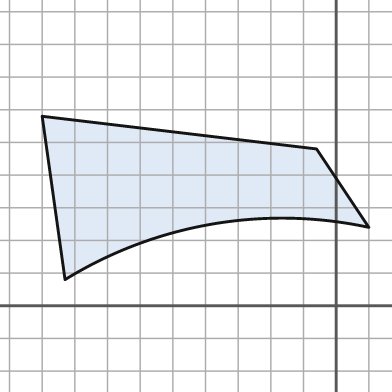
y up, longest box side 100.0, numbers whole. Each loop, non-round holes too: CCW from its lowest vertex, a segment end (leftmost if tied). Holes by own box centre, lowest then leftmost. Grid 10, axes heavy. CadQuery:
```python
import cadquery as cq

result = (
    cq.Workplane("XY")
    .moveTo(-83.0, 8.0)
    .threePointArc((-38.0, 25.0), (10.0, 24.0))
    .lineTo(-6.0, 48.0)
    .lineTo(-90.0, 58.0)
    .close()
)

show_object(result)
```